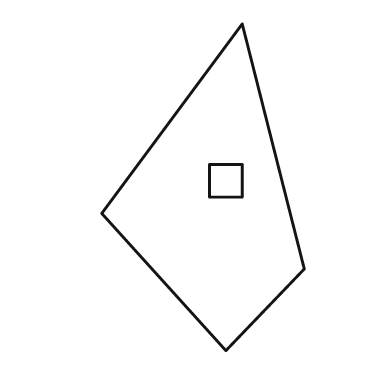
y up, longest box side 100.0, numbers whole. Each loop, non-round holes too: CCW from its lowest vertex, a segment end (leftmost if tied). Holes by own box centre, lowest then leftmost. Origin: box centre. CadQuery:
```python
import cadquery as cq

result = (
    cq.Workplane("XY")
    .moveTo(7.0, -50.0)
    .lineTo(31.0, -25.0)
    .lineTo(12.0, 50.0)
    .lineTo(-31.0, -8.0)
    .close()
    .moveTo(2.0, -3.0)
    .lineTo(12.0, -3.0)
    .lineTo(12.0, 7.0)
    .lineTo(2.0, 7.0)
    .close()
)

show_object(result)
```